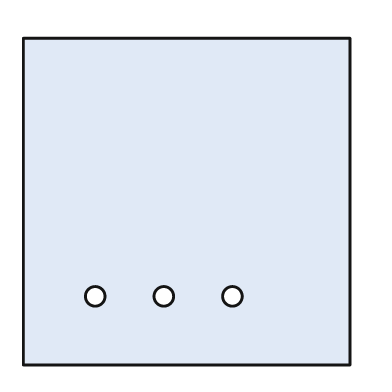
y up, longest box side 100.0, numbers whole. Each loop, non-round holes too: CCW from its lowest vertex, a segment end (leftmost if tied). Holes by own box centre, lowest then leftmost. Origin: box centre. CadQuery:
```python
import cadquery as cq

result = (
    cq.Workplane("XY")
    .moveTo(-50.0, -50.0)
    .lineTo(50.0, -50.0)
    .lineTo(50.0, 50.0)
    .lineTo(-50.0, 50.0)
    .close()
    .moveTo(-28.0, -29.0)
    .circle(3.0)
    .moveTo(-7.0, -29.0)
    .circle(3.0)
    .moveTo(14.0, -29.0)
    .circle(3.0)
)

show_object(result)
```